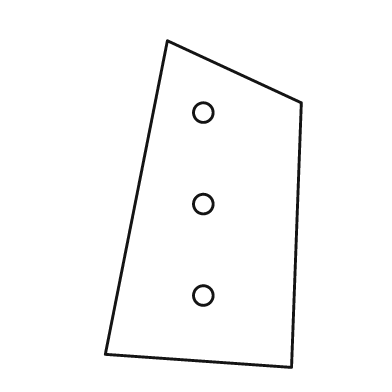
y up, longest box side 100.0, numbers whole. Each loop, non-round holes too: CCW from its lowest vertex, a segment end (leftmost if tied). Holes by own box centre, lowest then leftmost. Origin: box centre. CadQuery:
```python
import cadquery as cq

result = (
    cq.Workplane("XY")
    .moveTo(27.0, -50.0)
    .lineTo(30.0, 31.0)
    .lineTo(-11.0, 50.0)
    .lineTo(-30.0, -46.0)
    .close()
    .moveTo(0.0, -28.0)
    .circle(3.0)
    .moveTo(0.0, 0.0)
    .circle(3.0)
    .moveTo(0.0, 28.0)
    .circle(3.0)
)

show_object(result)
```